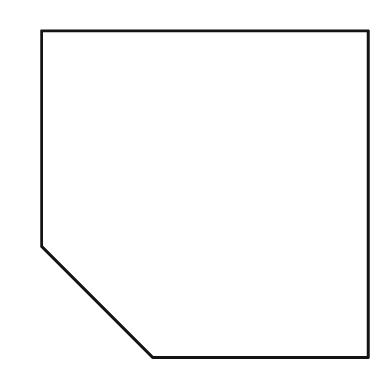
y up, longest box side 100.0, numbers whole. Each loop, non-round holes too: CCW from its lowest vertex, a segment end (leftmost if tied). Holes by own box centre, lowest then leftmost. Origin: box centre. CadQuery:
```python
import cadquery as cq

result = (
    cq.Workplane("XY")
    .moveTo(-16.0, -50.0)
    .lineTo(50.0, -50.0)
    .lineTo(50.0, 50.0)
    .lineTo(-50.0, 50.0)
    .lineTo(-50.0, -16.0)
    .close()
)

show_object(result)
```